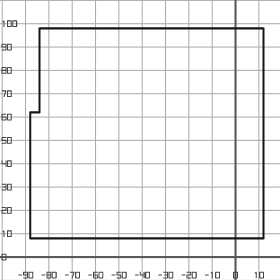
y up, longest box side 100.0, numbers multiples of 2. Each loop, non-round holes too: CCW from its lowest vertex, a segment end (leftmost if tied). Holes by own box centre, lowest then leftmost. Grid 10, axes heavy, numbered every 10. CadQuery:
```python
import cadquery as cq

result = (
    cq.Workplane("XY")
    .moveTo(-88.0, 8.0)
    .lineTo(12.0, 8.0)
    .lineTo(12.0, 98.0)
    .lineTo(-84.0, 98.0)
    .lineTo(-84.0, 62.0)
    .lineTo(-88.0, 62.0)
    .close()
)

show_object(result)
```